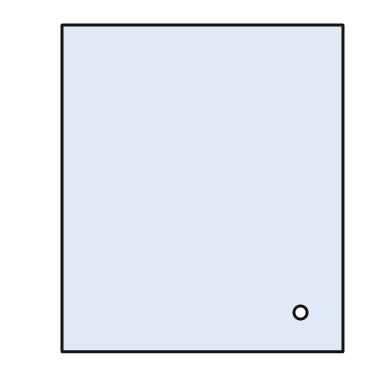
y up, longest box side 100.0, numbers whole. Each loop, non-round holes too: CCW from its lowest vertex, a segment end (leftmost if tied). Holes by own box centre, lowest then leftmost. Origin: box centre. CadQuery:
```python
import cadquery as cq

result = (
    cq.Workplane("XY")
    .moveTo(-43.0, -50.0)
    .lineTo(43.0, -50.0)
    .lineTo(43.0, 50.0)
    .lineTo(-43.0, 50.0)
    .close()
    .moveTo(30.0, -38.0)
    .circle(2.0)
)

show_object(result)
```